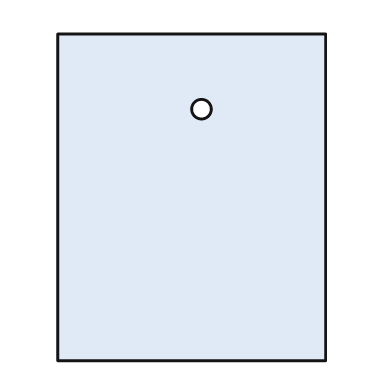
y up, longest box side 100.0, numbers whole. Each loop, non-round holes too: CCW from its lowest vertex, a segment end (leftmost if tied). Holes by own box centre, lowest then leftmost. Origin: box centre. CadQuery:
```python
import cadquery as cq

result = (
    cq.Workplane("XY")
    .moveTo(-41.0, -50.0)
    .lineTo(41.0, -50.0)
    .lineTo(41.0, 50.0)
    .lineTo(-41.0, 50.0)
    .close()
    .moveTo(3.0, 27.0)
    .circle(3.0)
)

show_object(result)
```